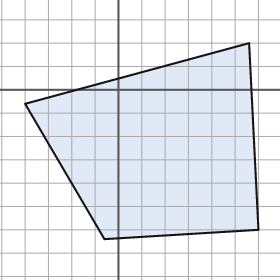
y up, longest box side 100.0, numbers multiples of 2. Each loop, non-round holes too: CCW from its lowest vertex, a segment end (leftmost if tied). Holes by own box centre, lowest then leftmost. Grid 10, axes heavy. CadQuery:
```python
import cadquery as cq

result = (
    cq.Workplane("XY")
    .moveTo(-6.0, -64.0)
    .lineTo(60.0, -60.0)
    .lineTo(56.0, 20.0)
    .lineTo(-40.0, -6.0)
    .close()
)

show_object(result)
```